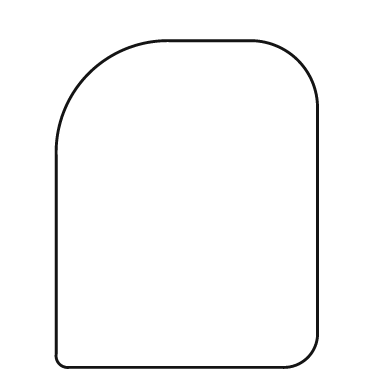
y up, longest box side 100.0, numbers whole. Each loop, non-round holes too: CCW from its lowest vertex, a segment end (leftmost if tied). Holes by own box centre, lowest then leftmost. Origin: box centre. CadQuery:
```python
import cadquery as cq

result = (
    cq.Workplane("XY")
    .moveTo(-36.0, -50.0)
    .lineTo(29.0, -50.0)
    .threePointArc((37.0, -47.0), (40.0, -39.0))
    .lineTo(40.0, 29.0)
    .threePointArc((34.0, 44.0), (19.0, 50.0))
    .lineTo(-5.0, 50.0)
    .threePointArc((-30.0, 40.0), (-40.0, 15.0))
    .lineTo(-40.0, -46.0)
    .threePointArc((-39.0, -49.0), (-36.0, -50.0))
    .close()
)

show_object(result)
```